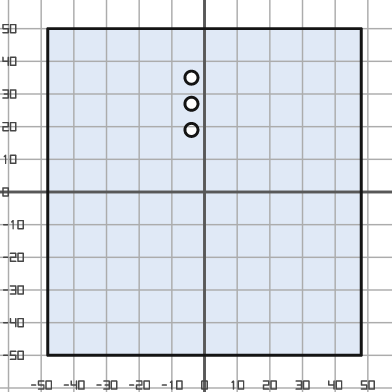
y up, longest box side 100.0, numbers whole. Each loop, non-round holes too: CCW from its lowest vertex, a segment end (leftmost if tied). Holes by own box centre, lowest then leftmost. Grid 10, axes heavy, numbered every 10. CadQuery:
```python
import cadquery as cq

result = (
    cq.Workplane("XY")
    .moveTo(-48.0, -50.0)
    .lineTo(48.0, -50.0)
    .lineTo(48.0, 50.0)
    .lineTo(-48.0, 50.0)
    .close()
    .moveTo(-4.0, 19.0)
    .circle(2.0)
    .moveTo(-4.0, 27.0)
    .circle(2.0)
    .moveTo(-4.0, 35.0)
    .circle(2.0)
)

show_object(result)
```